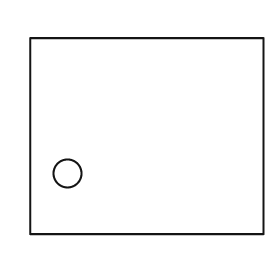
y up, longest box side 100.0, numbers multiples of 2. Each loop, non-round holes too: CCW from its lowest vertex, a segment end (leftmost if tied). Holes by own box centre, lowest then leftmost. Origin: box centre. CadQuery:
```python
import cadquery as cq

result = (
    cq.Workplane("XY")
    .moveTo(-50.0, -42.0)
    .lineTo(50.0, -42.0)
    .lineTo(50.0, 42.0)
    .lineTo(-50.0, 42.0)
    .close()
    .moveTo(-34.0, -16.0)
    .circle(6.0)
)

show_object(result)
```